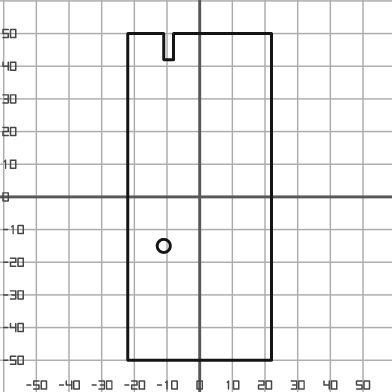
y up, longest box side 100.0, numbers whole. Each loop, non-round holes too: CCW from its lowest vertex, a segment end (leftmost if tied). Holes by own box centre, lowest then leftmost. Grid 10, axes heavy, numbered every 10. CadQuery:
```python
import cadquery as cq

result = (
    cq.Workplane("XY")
    .moveTo(-22.0, -50.0)
    .lineTo(22.0, -50.0)
    .lineTo(22.0, 50.0)
    .lineTo(-8.0, 50.0)
    .lineTo(-8.0, 42.0)
    .lineTo(-11.0, 42.0)
    .lineTo(-11.0, 50.0)
    .lineTo(-22.0, 50.0)
    .close()
    .moveTo(-11.0, -15.0)
    .circle(2.0)
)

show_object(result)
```